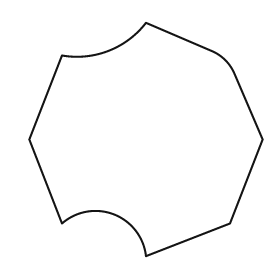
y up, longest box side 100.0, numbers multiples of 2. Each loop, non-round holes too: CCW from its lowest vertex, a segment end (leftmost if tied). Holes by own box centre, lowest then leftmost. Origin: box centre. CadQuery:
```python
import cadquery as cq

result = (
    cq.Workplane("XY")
    .moveTo(0.0, -50.0)
    .lineTo(36.0, -36.0)
    .lineTo(50.0, 0.0)
    .lineTo(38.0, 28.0)
    .threePointArc((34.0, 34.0), (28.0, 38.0))
    .lineTo(0.0, 50.0)
    .threePointArc((-16.0, 38.0), (-36.0, 36.0))
    .lineTo(-50.0, 0.0)
    .lineTo(-36.0, -36.0)
    .threePointArc((-14.0, -32.0), (0.0, -50.0))
    .close()
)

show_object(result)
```